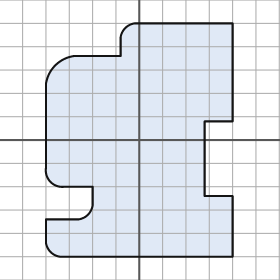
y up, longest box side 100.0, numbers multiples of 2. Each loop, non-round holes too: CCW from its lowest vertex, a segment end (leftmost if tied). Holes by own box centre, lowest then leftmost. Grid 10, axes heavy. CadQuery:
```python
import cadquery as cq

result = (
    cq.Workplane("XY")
    .moveTo(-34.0, -50.0)
    .lineTo(40.0, -50.0)
    .lineTo(40.0, -24.0)
    .lineTo(28.0, -24.0)
    .lineTo(28.0, 8.0)
    .lineTo(40.0, 8.0)
    .lineTo(40.0, 50.0)
    .lineTo(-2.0, 50.0)
    .threePointArc((-6.0, 48.0), (-8.0, 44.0))
    .lineTo(-8.0, 36.0)
    .lineTo(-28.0, 36.0)
    .threePointArc((-36.0, 32.0), (-40.0, 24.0))
    .lineTo(-40.0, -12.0)
    .threePointArc((-38.0, -18.0), (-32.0, -20.0))
    .lineTo(-20.0, -20.0)
    .lineTo(-20.0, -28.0)
    .threePointArc((-22.0, -32.0), (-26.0, -34.0))
    .lineTo(-40.0, -34.0)
    .lineTo(-40.0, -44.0)
    .threePointArc((-38.0, -48.0), (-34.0, -50.0))
    .close()
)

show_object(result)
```